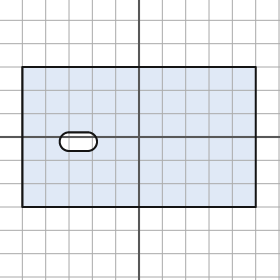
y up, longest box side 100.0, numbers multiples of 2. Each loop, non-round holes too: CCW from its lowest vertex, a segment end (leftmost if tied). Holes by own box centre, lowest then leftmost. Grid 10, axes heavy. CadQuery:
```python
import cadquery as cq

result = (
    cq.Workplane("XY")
    .moveTo(-50.0, -30.0)
    .lineTo(50.0, -30.0)
    .lineTo(50.0, 30.0)
    .lineTo(-50.0, 30.0)
    .close()
    .moveTo(-30.0, -6.0)
    .lineTo(-22.0, -6.0)
    .threePointArc((-18.0, -2.0), (-22.0, 2.0))
    .lineTo(-30.0, 2.0)
    .threePointArc((-34.0, -2.0), (-30.0, -6.0))
    .close()
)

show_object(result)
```